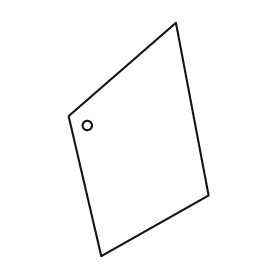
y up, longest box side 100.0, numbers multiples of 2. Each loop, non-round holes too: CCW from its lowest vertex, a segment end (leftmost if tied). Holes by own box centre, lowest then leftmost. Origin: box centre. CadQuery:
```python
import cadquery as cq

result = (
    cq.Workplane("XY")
    .moveTo(-16.0, -50.0)
    .lineTo(30.0, -24.0)
    .lineTo(16.0, 50.0)
    .lineTo(-30.0, 10.0)
    .close()
    .moveTo(-22.0, 6.0)
    .circle(2.0)
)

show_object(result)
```